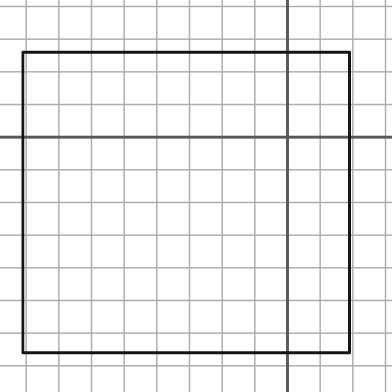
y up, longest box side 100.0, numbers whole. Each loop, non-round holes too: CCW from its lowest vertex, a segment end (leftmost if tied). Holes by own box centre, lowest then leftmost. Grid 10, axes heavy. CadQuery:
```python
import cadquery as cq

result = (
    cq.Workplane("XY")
    .moveTo(-81.0, -66.0)
    .lineTo(19.0, -66.0)
    .lineTo(19.0, 26.0)
    .lineTo(-81.0, 26.0)
    .close()
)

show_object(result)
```